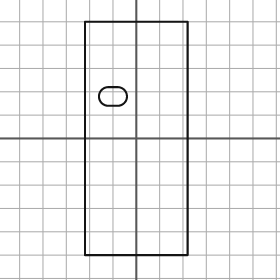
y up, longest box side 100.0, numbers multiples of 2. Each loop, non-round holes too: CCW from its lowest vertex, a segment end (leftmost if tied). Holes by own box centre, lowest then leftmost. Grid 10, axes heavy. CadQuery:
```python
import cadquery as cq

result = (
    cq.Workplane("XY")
    .moveTo(-22.0, -50.0)
    .lineTo(22.0, -50.0)
    .lineTo(22.0, 50.0)
    .lineTo(-22.0, 50.0)
    .close()
    .moveTo(-12.0, 14.0)
    .lineTo(-8.0, 14.0)
    .threePointArc((-4.0, 18.0), (-8.0, 22.0))
    .lineTo(-12.0, 22.0)
    .threePointArc((-16.0, 18.0), (-12.0, 14.0))
    .close()
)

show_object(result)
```